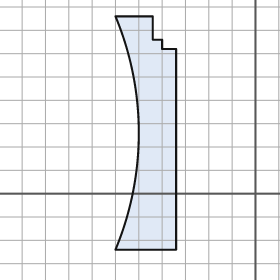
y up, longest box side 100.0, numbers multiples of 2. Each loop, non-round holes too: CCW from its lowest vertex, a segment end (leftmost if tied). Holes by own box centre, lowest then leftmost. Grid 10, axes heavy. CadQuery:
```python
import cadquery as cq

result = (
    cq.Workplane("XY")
    .moveTo(-60.0, -24.0)
    .lineTo(-34.0, -24.0)
    .lineTo(-34.0, 62.0)
    .lineTo(-40.0, 62.0)
    .lineTo(-40.0, 66.0)
    .lineTo(-44.0, 66.0)
    .lineTo(-44.0, 76.0)
    .lineTo(-60.0, 76.0)
    .threePointArc((-50.0, 26.0), (-60.0, -24.0))
    .close()
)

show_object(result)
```